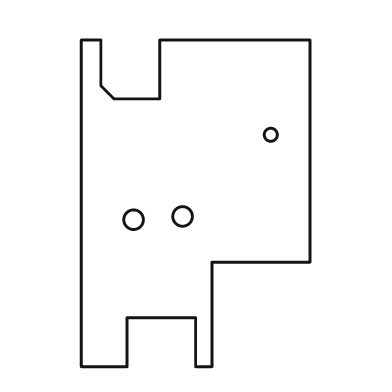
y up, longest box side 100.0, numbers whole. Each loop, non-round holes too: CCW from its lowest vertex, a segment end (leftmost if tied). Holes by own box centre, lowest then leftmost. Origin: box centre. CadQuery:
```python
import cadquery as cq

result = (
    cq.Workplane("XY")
    .moveTo(-35.0, -50.0)
    .lineTo(-21.0, -50.0)
    .lineTo(-21.0, -35.0)
    .lineTo(0.0, -35.0)
    .lineTo(0.0, -50.0)
    .lineTo(5.0, -50.0)
    .lineTo(5.0, -18.0)
    .lineTo(35.0, -18.0)
    .lineTo(35.0, 50.0)
    .lineTo(-11.0, 50.0)
    .lineTo(-11.0, 32.0)
    .lineTo(-25.0, 32.0)
    .lineTo(-29.0, 36.0)
    .lineTo(-29.0, 50.0)
    .lineTo(-35.0, 50.0)
    .close()
    .moveTo(-19.0, -5.0)
    .circle(3.0)
    .moveTo(-4.0, -4.0)
    .circle(3.0)
    .moveTo(23.0, 21.0)
    .circle(2.0)
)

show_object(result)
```